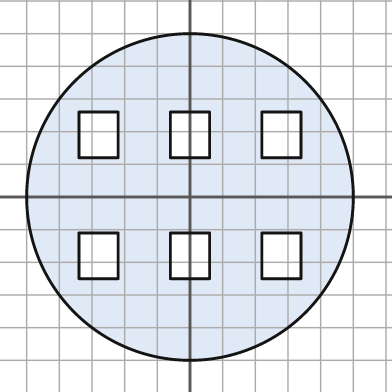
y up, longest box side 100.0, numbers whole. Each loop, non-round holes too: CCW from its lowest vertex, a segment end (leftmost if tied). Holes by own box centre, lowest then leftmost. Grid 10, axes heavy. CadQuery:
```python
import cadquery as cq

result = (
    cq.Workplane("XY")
    .moveTo(0.0, 0.0)
    .circle(50.0)
    .moveTo(-34.0, -25.0)
    .lineTo(-22.0, -25.0)
    .lineTo(-22.0, -11.0)
    .lineTo(-34.0, -11.0)
    .close()
    .moveTo(-6.0, -25.0)
    .lineTo(6.0, -25.0)
    .lineTo(6.0, -11.0)
    .lineTo(-6.0, -11.0)
    .close()
    .moveTo(22.0, -25.0)
    .lineTo(34.0, -25.0)
    .lineTo(34.0, -11.0)
    .lineTo(22.0, -11.0)
    .close()
    .moveTo(-34.0, 12.0)
    .lineTo(-22.0, 12.0)
    .lineTo(-22.0, 26.0)
    .lineTo(-34.0, 26.0)
    .close()
    .moveTo(-6.0, 12.0)
    .lineTo(6.0, 12.0)
    .lineTo(6.0, 26.0)
    .lineTo(-6.0, 26.0)
    .close()
    .moveTo(22.0, 12.0)
    .lineTo(34.0, 12.0)
    .lineTo(34.0, 26.0)
    .lineTo(22.0, 26.0)
    .close()
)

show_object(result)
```